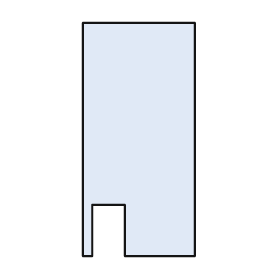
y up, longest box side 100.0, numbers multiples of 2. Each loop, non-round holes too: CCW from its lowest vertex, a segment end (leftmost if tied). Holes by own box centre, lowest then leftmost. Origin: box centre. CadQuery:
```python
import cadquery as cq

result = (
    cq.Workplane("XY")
    .moveTo(-24.0, -50.0)
    .lineTo(-20.0, -50.0)
    .lineTo(-20.0, -28.0)
    .lineTo(-6.0, -28.0)
    .lineTo(-6.0, -50.0)
    .lineTo(24.0, -50.0)
    .lineTo(24.0, 50.0)
    .lineTo(-24.0, 50.0)
    .close()
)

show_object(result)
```